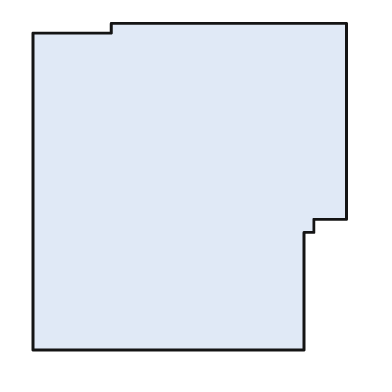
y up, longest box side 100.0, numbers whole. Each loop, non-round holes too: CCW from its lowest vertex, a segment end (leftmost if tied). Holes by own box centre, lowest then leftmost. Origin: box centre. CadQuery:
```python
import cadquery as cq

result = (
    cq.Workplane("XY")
    .moveTo(-48.0, -50.0)
    .lineTo(35.0, -50.0)
    .lineTo(35.0, -14.0)
    .lineTo(38.0, -14.0)
    .lineTo(38.0, -10.0)
    .lineTo(48.0, -10.0)
    .lineTo(48.0, 50.0)
    .lineTo(-24.0, 50.0)
    .lineTo(-24.0, 47.0)
    .lineTo(-48.0, 47.0)
    .close()
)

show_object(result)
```